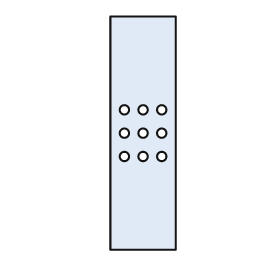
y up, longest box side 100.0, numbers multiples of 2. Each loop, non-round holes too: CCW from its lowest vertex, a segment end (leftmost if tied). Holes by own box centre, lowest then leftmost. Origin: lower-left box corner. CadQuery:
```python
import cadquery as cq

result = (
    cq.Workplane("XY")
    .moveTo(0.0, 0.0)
    .lineTo(28.0, 0.0)
    .lineTo(28.0, 100.0)
    .lineTo(0.0, 100.0)
    .close()
    .moveTo(6.0, 40.0)
    .circle(2.0)
    .moveTo(14.0, 40.0)
    .circle(2.0)
    .moveTo(22.0, 40.0)
    .circle(2.0)
    .moveTo(6.0, 50.0)
    .circle(2.0)
    .moveTo(14.0, 50.0)
    .circle(2.0)
    .moveTo(22.0, 50.0)
    .circle(2.0)
    .moveTo(6.0, 60.0)
    .circle(2.0)
    .moveTo(14.0, 60.0)
    .circle(2.0)
    .moveTo(22.0, 60.0)
    .circle(2.0)
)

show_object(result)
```